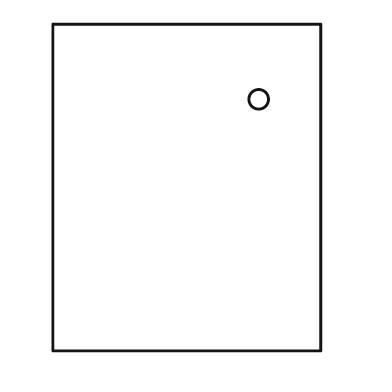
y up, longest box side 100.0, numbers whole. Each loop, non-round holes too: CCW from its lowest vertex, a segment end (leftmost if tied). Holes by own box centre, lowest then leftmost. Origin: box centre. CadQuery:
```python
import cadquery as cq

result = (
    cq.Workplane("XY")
    .moveTo(-41.0, -50.0)
    .lineTo(41.0, -50.0)
    .lineTo(41.0, 50.0)
    .lineTo(-41.0, 50.0)
    .close()
    .moveTo(22.0, 27.0)
    .circle(3.0)
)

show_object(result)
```